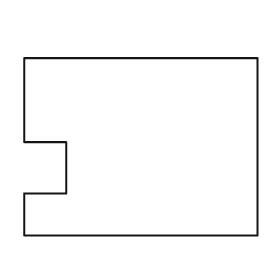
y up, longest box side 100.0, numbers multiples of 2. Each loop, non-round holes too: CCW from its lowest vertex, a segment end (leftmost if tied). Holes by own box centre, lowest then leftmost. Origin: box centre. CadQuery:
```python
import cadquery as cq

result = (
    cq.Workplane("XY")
    .moveTo(-50.0, -38.0)
    .lineTo(50.0, -38.0)
    .lineTo(50.0, 38.0)
    .lineTo(-50.0, 38.0)
    .lineTo(-50.0, 2.0)
    .lineTo(-32.0, 2.0)
    .lineTo(-32.0, -20.0)
    .lineTo(-50.0, -20.0)
    .close()
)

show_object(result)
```